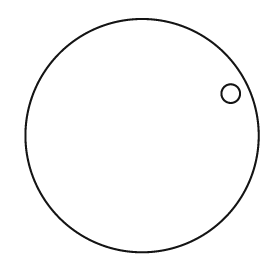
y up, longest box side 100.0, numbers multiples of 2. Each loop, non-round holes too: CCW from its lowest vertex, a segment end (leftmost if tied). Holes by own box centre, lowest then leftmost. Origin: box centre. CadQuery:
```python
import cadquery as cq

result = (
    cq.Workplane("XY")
    .moveTo(0.0, 0.0)
    .circle(50.0)
    .moveTo(38.0, 18.0)
    .circle(4.0)
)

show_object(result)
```